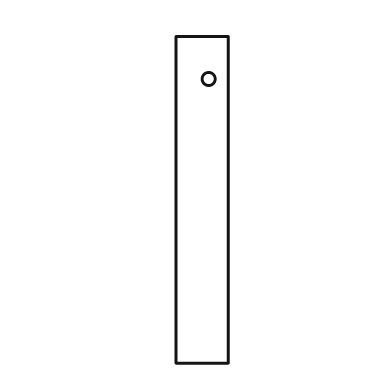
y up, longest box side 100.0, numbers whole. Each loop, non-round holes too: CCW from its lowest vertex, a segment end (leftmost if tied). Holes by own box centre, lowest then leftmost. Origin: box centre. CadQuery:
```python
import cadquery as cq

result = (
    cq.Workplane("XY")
    .moveTo(-8.0, -50.0)
    .lineTo(8.0, -50.0)
    .lineTo(8.0, 50.0)
    .lineTo(-8.0, 50.0)
    .close()
    .moveTo(2.0, 37.0)
    .circle(2.0)
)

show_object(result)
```